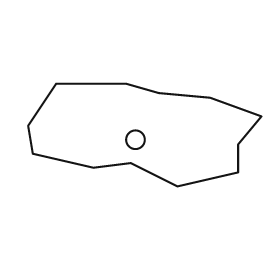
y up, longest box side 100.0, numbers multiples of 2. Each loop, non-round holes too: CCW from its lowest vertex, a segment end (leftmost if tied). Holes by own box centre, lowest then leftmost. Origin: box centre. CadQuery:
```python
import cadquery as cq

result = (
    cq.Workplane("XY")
    .moveTo(14.0, -22.0)
    .lineTo(40.0, -16.0)
    .lineTo(40.0, -4.0)
    .lineTo(50.0, 8.0)
    .lineTo(28.0, 16.0)
    .lineTo(6.0, 18.0)
    .lineTo(-8.0, 22.0)
    .lineTo(-38.0, 22.0)
    .lineTo(-50.0, 4.0)
    .lineTo(-48.0, -8.0)
    .lineTo(-22.0, -14.0)
    .lineTo(-6.0, -12.0)
    .close()
    .moveTo(-4.0, -2.0)
    .circle(4.0)
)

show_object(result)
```